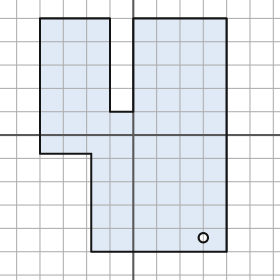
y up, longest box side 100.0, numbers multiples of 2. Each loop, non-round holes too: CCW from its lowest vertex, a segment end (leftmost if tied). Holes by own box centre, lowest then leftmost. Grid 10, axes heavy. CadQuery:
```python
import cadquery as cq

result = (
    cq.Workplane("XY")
    .moveTo(-18.0, -50.0)
    .lineTo(40.0, -50.0)
    .lineTo(40.0, 50.0)
    .lineTo(0.0, 50.0)
    .lineTo(0.0, 10.0)
    .lineTo(-10.0, 10.0)
    .lineTo(-10.0, 50.0)
    .lineTo(-40.0, 50.0)
    .lineTo(-40.0, -8.0)
    .lineTo(-18.0, -8.0)
    .close()
    .moveTo(30.0, -44.0)
    .circle(2.0)
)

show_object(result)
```